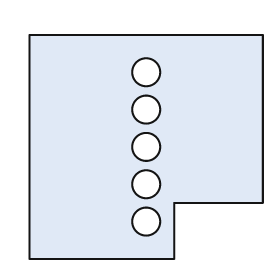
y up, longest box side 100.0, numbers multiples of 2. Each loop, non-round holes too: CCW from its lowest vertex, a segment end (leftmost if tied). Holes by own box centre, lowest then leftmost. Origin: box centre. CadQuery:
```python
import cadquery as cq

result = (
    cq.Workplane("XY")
    .moveTo(-50.0, -48.0)
    .lineTo(12.0, -48.0)
    .lineTo(12.0, -24.0)
    .lineTo(50.0, -24.0)
    .lineTo(50.0, 48.0)
    .lineTo(-50.0, 48.0)
    .close()
    .moveTo(0.0, -32.0)
    .circle(6.0)
    .moveTo(0.0, -16.0)
    .circle(6.0)
    .moveTo(0.0, 0.0)
    .circle(6.0)
    .moveTo(0.0, 16.0)
    .circle(6.0)
    .moveTo(0.0, 32.0)
    .circle(6.0)
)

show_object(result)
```